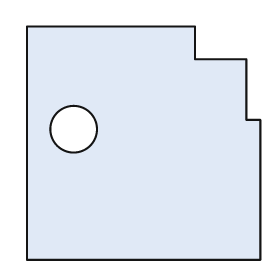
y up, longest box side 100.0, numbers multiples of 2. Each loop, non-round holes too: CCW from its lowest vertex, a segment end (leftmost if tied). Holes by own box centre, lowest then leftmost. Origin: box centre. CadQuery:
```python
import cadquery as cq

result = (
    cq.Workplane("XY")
    .moveTo(-50.0, -50.0)
    .lineTo(50.0, -50.0)
    .lineTo(50.0, 10.0)
    .lineTo(44.0, 10.0)
    .lineTo(44.0, 36.0)
    .lineTo(22.0, 36.0)
    .lineTo(22.0, 50.0)
    .lineTo(-50.0, 50.0)
    .close()
    .moveTo(-30.0, 6.0)
    .circle(10.0)
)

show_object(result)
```